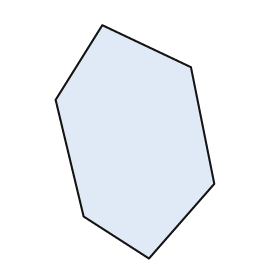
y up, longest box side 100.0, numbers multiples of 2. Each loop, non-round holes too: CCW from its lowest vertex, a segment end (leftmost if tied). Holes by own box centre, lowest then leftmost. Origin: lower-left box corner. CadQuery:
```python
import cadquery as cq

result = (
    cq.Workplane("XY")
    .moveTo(40.0, 0.0)
    .lineTo(68.0, 32.0)
    .lineTo(58.0, 82.0)
    .lineTo(20.0, 100.0)
    .lineTo(0.0, 68.0)
    .lineTo(12.0, 18.0)
    .close()
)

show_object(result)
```